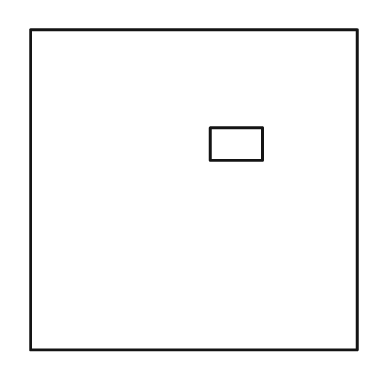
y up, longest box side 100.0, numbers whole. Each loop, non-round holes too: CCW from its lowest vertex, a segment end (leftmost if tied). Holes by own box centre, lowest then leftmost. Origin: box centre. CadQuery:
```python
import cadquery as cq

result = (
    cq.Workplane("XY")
    .moveTo(-50.0, -49.0)
    .lineTo(50.0, -49.0)
    .lineTo(50.0, 49.0)
    .lineTo(-50.0, 49.0)
    .close()
    .moveTo(5.0, 9.0)
    .lineTo(21.0, 9.0)
    .lineTo(21.0, 19.0)
    .lineTo(5.0, 19.0)
    .close()
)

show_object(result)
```